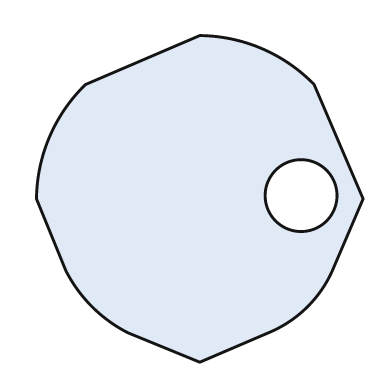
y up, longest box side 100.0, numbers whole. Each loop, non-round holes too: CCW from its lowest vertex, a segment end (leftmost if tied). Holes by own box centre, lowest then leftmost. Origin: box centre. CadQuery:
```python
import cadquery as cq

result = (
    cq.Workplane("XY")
    .moveTo(0.0, -50.0)
    .lineTo(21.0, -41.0)
    .threePointArc((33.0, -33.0), (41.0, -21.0))
    .lineTo(50.0, 0.0)
    .lineTo(35.0, 35.0)
    .threePointArc((19.0, 46.0), (0.0, 50.0))
    .lineTo(-35.0, 35.0)
    .threePointArc((-46.0, 19.0), (-50.0, 0.0))
    .lineTo(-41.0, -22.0)
    .threePointArc((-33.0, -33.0), (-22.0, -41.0))
    .close()
    .moveTo(31.0, 1.0)
    .circle(11.0)
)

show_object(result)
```